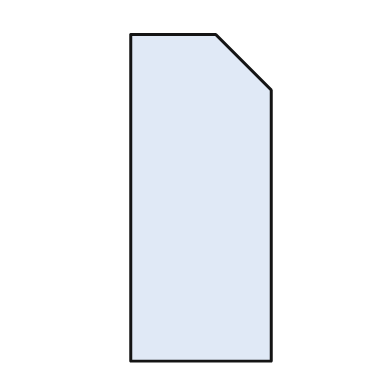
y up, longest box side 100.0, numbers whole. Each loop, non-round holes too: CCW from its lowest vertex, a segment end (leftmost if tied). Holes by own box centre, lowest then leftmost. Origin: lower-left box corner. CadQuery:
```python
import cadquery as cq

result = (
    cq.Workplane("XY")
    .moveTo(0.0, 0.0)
    .lineTo(43.0, 0.0)
    .lineTo(43.0, 83.0)
    .lineTo(26.0, 100.0)
    .lineTo(0.0, 100.0)
    .close()
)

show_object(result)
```